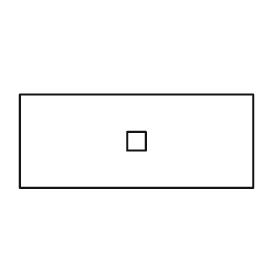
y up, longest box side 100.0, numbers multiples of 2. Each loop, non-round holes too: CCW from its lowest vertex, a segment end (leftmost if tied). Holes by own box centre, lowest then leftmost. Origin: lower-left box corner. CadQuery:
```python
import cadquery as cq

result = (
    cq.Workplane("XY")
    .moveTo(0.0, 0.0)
    .lineTo(100.0, 0.0)
    .lineTo(100.0, 40.0)
    .lineTo(0.0, 40.0)
    .close()
    .moveTo(46.0, 16.0)
    .lineTo(54.0, 16.0)
    .lineTo(54.0, 24.0)
    .lineTo(46.0, 24.0)
    .close()
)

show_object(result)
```